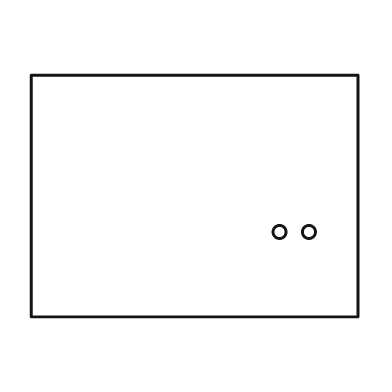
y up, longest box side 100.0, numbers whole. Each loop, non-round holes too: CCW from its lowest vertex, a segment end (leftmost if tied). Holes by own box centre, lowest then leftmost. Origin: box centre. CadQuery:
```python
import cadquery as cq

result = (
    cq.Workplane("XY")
    .moveTo(-50.0, -37.0)
    .lineTo(50.0, -37.0)
    .lineTo(50.0, 37.0)
    .lineTo(-50.0, 37.0)
    .close()
    .moveTo(26.0, -11.0)
    .circle(2.0)
    .moveTo(35.0, -11.0)
    .circle(2.0)
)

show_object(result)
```